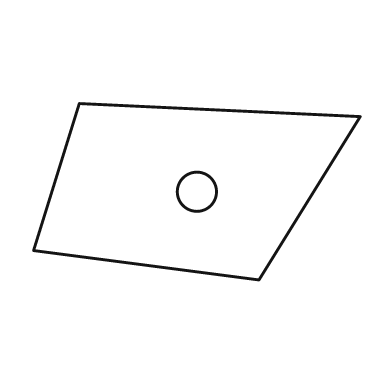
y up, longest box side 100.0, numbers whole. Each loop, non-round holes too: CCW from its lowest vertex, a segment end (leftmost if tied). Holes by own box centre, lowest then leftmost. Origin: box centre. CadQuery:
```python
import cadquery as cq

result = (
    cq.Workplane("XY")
    .moveTo(19.0, -27.0)
    .lineTo(50.0, 23.0)
    .lineTo(-36.0, 27.0)
    .lineTo(-50.0, -18.0)
    .close()
    .moveTo(0.0, 0.0)
    .circle(6.0)
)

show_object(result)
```